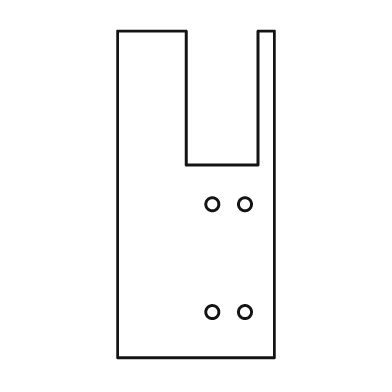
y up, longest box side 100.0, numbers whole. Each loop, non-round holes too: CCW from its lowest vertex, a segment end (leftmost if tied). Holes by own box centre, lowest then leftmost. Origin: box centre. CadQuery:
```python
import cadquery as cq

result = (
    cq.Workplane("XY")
    .moveTo(-24.0, -50.0)
    .lineTo(24.0, -50.0)
    .lineTo(24.0, 50.0)
    .lineTo(19.0, 50.0)
    .lineTo(19.0, 9.0)
    .lineTo(-3.0, 9.0)
    .lineTo(-3.0, 50.0)
    .lineTo(-24.0, 50.0)
    .close()
    .moveTo(5.0, -36.0)
    .circle(2.0)
    .moveTo(15.0, -36.0)
    .circle(2.0)
    .moveTo(5.0, -3.0)
    .circle(2.0)
    .moveTo(15.0, -3.0)
    .circle(2.0)
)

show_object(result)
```